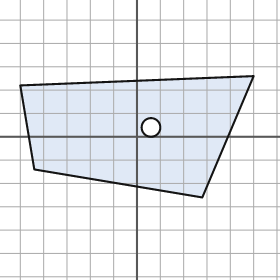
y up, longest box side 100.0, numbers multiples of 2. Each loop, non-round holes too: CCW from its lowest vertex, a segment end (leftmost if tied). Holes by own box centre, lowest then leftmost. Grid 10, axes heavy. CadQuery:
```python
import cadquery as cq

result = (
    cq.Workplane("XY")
    .moveTo(28.0, -26.0)
    .lineTo(50.0, 26.0)
    .lineTo(-50.0, 22.0)
    .lineTo(-44.0, -14.0)
    .close()
    .moveTo(6.0, 4.0)
    .circle(4.0)
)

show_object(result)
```